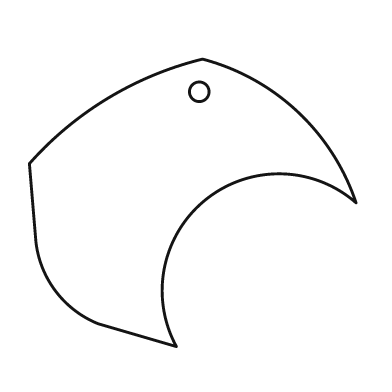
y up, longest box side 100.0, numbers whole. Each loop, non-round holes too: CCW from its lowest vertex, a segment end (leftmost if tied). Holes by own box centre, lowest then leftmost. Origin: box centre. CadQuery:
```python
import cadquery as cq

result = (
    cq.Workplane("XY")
    .moveTo(-5.0, -44.0)
    .threePointArc((4.0, 1.0), (50.0, 0.0))
    .threePointArc((32.0, 28.0), (3.0, 44.0))
    .threePointArc((-26.0, 32.0), (-50.0, 12.0))
    .lineTo(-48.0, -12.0)
    .threePointArc((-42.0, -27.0), (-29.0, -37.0))
    .close()
    .moveTo(2.0, 34.0)
    .circle(3.0)
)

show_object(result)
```